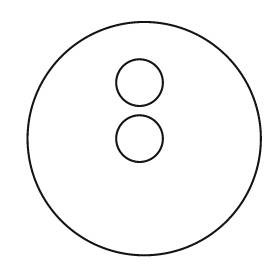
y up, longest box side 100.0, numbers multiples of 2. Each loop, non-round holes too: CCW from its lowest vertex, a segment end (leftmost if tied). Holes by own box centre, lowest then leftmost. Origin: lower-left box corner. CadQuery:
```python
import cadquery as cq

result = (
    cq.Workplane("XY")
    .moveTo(50.0, 50.0)
    .circle(50.0)
    .moveTo(48.0, 50.0)
    .circle(10.0)
    .moveTo(48.0, 74.0)
    .circle(10.0)
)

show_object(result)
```